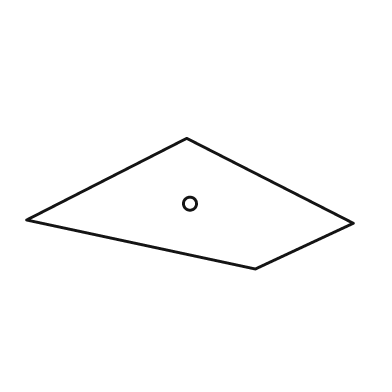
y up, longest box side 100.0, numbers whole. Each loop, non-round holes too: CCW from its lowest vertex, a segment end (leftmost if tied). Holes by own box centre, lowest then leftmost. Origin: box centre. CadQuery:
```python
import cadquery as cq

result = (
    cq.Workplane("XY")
    .moveTo(20.0, -20.0)
    .lineTo(50.0, -6.0)
    .lineTo(-1.0, 20.0)
    .lineTo(-50.0, -5.0)
    .close()
    .moveTo(0.0, 0.0)
    .circle(2.0)
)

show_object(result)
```